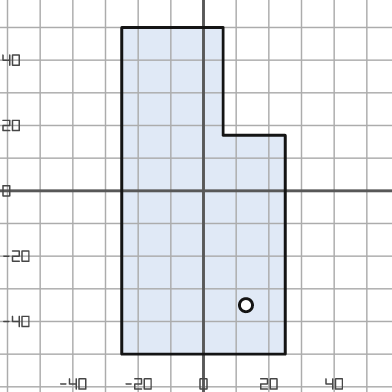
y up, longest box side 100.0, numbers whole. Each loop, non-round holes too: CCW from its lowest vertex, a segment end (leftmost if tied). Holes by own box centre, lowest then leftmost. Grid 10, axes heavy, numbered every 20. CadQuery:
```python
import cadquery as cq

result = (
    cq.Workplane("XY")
    .moveTo(-25.0, -50.0)
    .lineTo(25.0, -50.0)
    .lineTo(25.0, 17.0)
    .lineTo(6.0, 17.0)
    .lineTo(6.0, 50.0)
    .lineTo(-25.0, 50.0)
    .close()
    .moveTo(13.0, -35.0)
    .circle(2.0)
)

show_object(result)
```